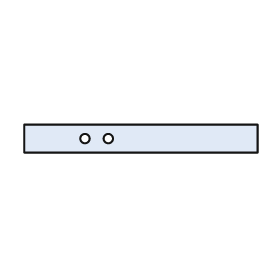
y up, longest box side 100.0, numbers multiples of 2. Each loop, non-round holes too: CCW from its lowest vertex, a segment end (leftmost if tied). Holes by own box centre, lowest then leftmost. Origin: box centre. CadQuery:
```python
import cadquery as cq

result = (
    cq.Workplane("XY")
    .moveTo(-50.0, -6.0)
    .lineTo(50.0, -6.0)
    .lineTo(50.0, 6.0)
    .lineTo(-50.0, 6.0)
    .close()
    .moveTo(-24.0, 0.0)
    .circle(2.0)
    .moveTo(-14.0, 0.0)
    .circle(2.0)
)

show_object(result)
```